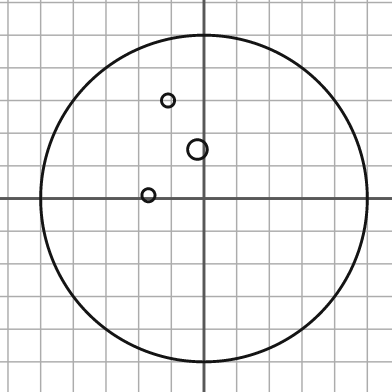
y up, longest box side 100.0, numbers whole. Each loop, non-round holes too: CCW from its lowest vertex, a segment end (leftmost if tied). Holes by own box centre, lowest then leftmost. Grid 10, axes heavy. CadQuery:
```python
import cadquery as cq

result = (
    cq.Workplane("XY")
    .moveTo(0.0, 0.0)
    .circle(50.0)
    .moveTo(-17.0, 1.0)
    .circle(2.0)
    .moveTo(-2.0, 15.0)
    .circle(3.0)
    .moveTo(-11.0, 30.0)
    .circle(2.0)
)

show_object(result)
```